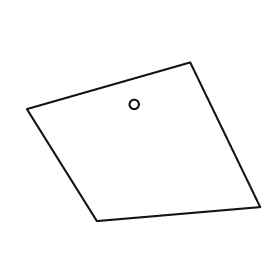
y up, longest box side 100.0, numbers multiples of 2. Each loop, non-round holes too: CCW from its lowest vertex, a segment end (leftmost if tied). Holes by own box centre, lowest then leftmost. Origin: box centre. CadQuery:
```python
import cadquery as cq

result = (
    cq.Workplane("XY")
    .moveTo(-20.0, -34.0)
    .lineTo(50.0, -28.0)
    .lineTo(20.0, 34.0)
    .lineTo(-50.0, 14.0)
    .close()
    .moveTo(-4.0, 16.0)
    .circle(2.0)
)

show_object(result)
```